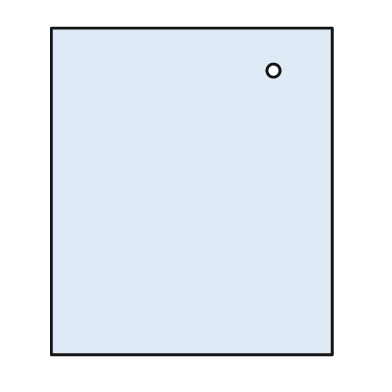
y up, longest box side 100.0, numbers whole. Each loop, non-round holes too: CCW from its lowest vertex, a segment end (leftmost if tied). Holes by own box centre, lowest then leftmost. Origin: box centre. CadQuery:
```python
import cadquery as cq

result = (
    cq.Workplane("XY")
    .moveTo(-43.0, -50.0)
    .lineTo(43.0, -50.0)
    .lineTo(43.0, 50.0)
    .lineTo(-43.0, 50.0)
    .close()
    .moveTo(25.0, 37.0)
    .circle(2.0)
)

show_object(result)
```